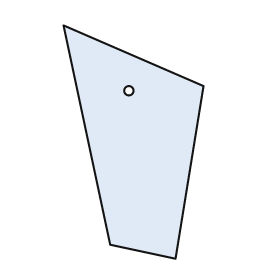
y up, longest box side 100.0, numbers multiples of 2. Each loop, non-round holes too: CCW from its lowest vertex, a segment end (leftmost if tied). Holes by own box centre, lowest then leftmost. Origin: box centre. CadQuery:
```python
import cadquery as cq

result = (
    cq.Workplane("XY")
    .moveTo(18.0, -50.0)
    .lineTo(30.0, 24.0)
    .lineTo(-30.0, 50.0)
    .lineTo(-10.0, -44.0)
    .close()
    .moveTo(-2.0, 22.0)
    .circle(2.0)
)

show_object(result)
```